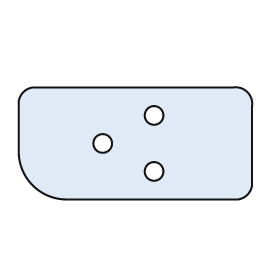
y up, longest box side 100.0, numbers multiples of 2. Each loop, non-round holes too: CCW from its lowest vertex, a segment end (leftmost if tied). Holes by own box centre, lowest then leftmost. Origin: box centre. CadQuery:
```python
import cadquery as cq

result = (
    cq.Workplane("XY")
    .moveTo(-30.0, -24.0)
    .lineTo(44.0, -24.0)
    .threePointArc((48.0, -22.0), (50.0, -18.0))
    .lineTo(50.0, 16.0)
    .threePointArc((48.0, 22.0), (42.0, 24.0))
    .lineTo(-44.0, 24.0)
    .threePointArc((-48.0, 22.0), (-50.0, 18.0))
    .lineTo(-50.0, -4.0)
    .threePointArc((-44.0, -18.0), (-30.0, -24.0))
    .close()
    .moveTo(8.0, -12.0)
    .circle(4.0)
    .moveTo(-14.0, 0.0)
    .circle(4.0)
    .moveTo(8.0, 12.0)
    .circle(4.0)
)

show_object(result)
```